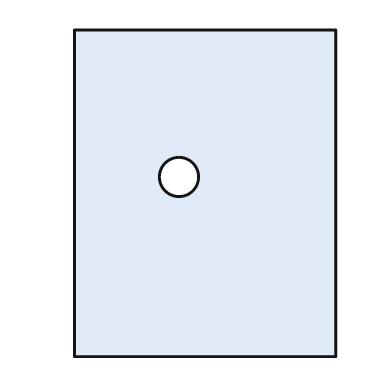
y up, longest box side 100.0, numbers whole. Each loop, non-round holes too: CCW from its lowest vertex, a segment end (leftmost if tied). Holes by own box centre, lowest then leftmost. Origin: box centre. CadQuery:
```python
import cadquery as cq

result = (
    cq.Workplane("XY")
    .moveTo(-40.0, -50.0)
    .lineTo(40.0, -50.0)
    .lineTo(40.0, 50.0)
    .lineTo(-40.0, 50.0)
    .close()
    .moveTo(-8.0, 5.0)
    .circle(6.0)
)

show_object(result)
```